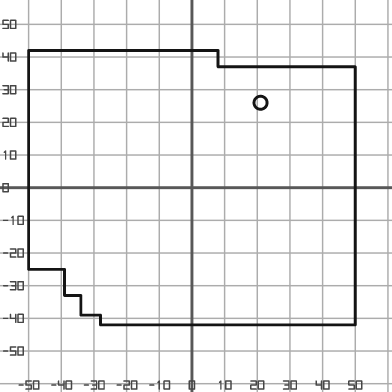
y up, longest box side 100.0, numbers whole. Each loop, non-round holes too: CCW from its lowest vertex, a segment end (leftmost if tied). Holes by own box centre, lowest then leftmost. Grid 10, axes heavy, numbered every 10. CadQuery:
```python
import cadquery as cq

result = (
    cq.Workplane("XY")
    .moveTo(-28.0, -42.0)
    .lineTo(50.0, -42.0)
    .lineTo(50.0, 37.0)
    .lineTo(8.0, 37.0)
    .lineTo(8.0, 42.0)
    .lineTo(-50.0, 42.0)
    .lineTo(-50.0, -25.0)
    .lineTo(-39.0, -25.0)
    .lineTo(-39.0, -33.0)
    .lineTo(-34.0, -33.0)
    .lineTo(-34.0, -39.0)
    .lineTo(-28.0, -39.0)
    .close()
    .moveTo(21.0, 26.0)
    .circle(2.0)
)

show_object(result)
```